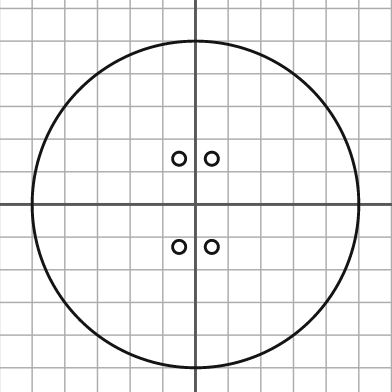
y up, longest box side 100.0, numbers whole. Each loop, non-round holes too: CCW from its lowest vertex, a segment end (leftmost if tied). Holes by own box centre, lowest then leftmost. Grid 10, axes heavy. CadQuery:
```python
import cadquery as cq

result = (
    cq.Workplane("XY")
    .moveTo(0.0, 0.0)
    .circle(50.0)
    .moveTo(-5.0, -13.0)
    .circle(2.0)
    .moveTo(5.0, -13.0)
    .circle(2.0)
    .moveTo(-5.0, 14.0)
    .circle(2.0)
    .moveTo(5.0, 14.0)
    .circle(2.0)
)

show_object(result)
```